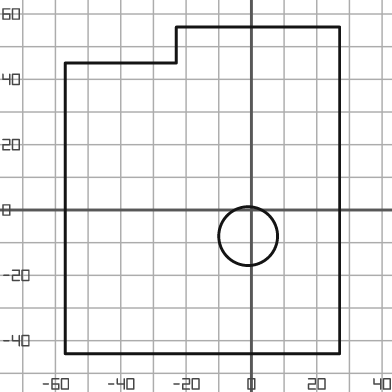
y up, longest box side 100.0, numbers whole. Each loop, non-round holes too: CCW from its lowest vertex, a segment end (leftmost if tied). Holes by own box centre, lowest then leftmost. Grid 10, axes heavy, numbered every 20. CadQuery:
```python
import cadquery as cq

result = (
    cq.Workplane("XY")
    .moveTo(-57.0, -44.0)
    .lineTo(27.0, -44.0)
    .lineTo(27.0, 56.0)
    .lineTo(-23.0, 56.0)
    .lineTo(-23.0, 45.0)
    .lineTo(-57.0, 45.0)
    .close()
    .moveTo(-1.0, -8.0)
    .circle(9.0)
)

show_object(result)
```